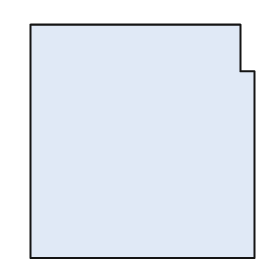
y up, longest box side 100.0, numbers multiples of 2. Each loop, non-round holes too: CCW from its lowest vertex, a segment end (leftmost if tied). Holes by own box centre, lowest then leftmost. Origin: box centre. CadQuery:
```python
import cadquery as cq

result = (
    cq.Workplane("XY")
    .moveTo(-48.0, -50.0)
    .lineTo(48.0, -50.0)
    .lineTo(48.0, 30.0)
    .lineTo(42.0, 30.0)
    .lineTo(42.0, 50.0)
    .lineTo(-48.0, 50.0)
    .close()
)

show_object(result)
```